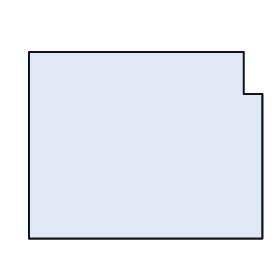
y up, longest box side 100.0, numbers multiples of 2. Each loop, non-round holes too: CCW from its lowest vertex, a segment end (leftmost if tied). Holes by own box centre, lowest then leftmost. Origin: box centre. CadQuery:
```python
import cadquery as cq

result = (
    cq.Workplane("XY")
    .moveTo(-50.0, -40.0)
    .lineTo(50.0, -40.0)
    .lineTo(50.0, 22.0)
    .lineTo(42.0, 22.0)
    .lineTo(42.0, 40.0)
    .lineTo(-50.0, 40.0)
    .close()
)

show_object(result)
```